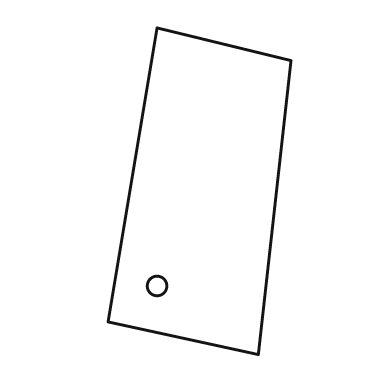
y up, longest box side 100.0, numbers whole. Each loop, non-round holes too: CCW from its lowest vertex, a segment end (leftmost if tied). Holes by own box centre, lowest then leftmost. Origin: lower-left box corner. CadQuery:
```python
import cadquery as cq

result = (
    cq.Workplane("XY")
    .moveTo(46.0, 0.0)
    .lineTo(56.0, 90.0)
    .lineTo(15.0, 100.0)
    .lineTo(0.0, 10.0)
    .close()
    .moveTo(15.0, 21.0)
    .circle(3.0)
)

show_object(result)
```